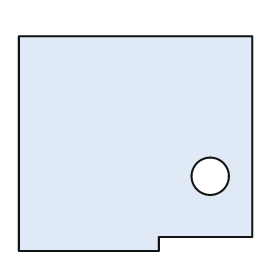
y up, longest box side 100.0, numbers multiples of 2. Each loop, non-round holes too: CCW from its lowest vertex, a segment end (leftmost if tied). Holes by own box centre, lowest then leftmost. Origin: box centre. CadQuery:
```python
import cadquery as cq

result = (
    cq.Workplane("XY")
    .moveTo(-50.0, -46.0)
    .lineTo(10.0, -46.0)
    .lineTo(10.0, -40.0)
    .lineTo(50.0, -40.0)
    .lineTo(50.0, 46.0)
    .lineTo(-50.0, 46.0)
    .close()
    .moveTo(32.0, -14.0)
    .circle(8.0)
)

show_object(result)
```